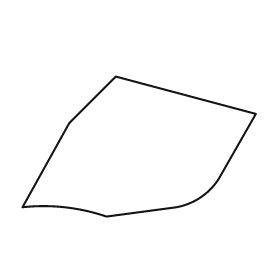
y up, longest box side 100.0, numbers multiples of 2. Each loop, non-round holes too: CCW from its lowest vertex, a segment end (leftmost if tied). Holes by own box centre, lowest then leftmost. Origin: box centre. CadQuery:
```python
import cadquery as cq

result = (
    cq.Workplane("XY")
    .moveTo(-14.0, -30.0)
    .lineTo(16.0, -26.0)
    .threePointArc((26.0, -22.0), (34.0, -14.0))
    .lineTo(50.0, 14.0)
    .lineTo(-10.0, 30.0)
    .lineTo(-30.0, 10.0)
    .lineTo(-50.0, -26.0)
    .threePointArc((-32.0, -26.0), (-14.0, -30.0))
    .close()
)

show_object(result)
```